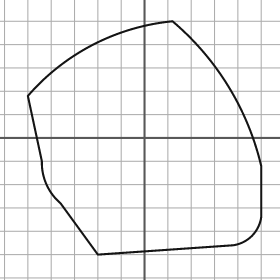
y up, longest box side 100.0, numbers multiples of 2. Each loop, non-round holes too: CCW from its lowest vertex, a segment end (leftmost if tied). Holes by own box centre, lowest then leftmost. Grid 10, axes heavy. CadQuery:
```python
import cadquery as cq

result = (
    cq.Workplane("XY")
    .moveTo(-20.0, -50.0)
    .lineTo(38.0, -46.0)
    .threePointArc((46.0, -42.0), (50.0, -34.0))
    .lineTo(50.0, -12.0)
    .threePointArc((36.0, 22.0), (12.0, 50.0))
    .threePointArc((-22.0, 40.0), (-50.0, 18.0))
    .lineTo(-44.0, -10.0)
    .threePointArc((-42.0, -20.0), (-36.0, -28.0))
    .close()
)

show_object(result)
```